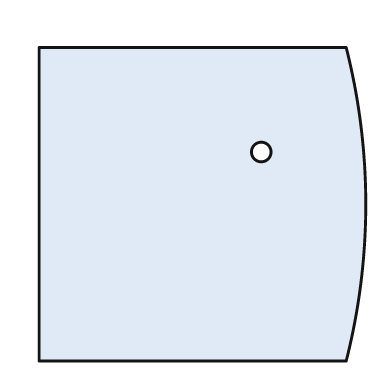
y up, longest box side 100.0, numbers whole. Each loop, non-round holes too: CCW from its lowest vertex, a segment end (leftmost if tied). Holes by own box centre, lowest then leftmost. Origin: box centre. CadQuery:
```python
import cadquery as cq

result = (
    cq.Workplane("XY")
    .moveTo(-50.0, -48.0)
    .lineTo(44.0, -48.0)
    .threePointArc((50.0, 0.0), (44.0, 48.0))
    .lineTo(-50.0, 48.0)
    .close()
    .moveTo(18.0, 16.0)
    .circle(3.0)
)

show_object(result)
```